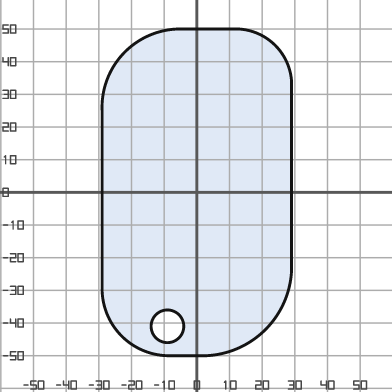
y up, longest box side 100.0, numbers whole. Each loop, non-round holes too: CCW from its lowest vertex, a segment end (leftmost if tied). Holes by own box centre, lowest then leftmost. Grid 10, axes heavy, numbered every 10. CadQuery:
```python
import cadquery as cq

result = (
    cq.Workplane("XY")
    .moveTo(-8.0, -50.0)
    .lineTo(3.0, -50.0)
    .threePointArc((21.0, -42.0), (29.0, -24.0))
    .lineTo(29.0, 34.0)
    .threePointArc((24.0, 45.0), (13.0, 50.0))
    .lineTo(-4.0, 50.0)
    .threePointArc((-22.0, 43.0), (-29.0, 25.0))
    .lineTo(-29.0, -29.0)
    .threePointArc((-23.0, -44.0), (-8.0, -50.0))
    .close()
    .moveTo(-9.0, -41.0)
    .circle(5.0)
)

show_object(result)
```